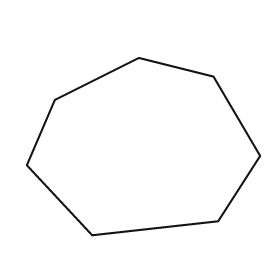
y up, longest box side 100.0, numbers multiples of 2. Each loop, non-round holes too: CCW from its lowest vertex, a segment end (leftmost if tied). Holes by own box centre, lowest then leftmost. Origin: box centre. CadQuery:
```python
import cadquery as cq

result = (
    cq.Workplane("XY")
    .moveTo(-22.0, -38.0)
    .lineTo(32.0, -32.0)
    .lineTo(50.0, -4.0)
    .lineTo(30.0, 30.0)
    .lineTo(-2.0, 38.0)
    .lineTo(-38.0, 20.0)
    .lineTo(-50.0, -8.0)
    .close()
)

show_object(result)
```